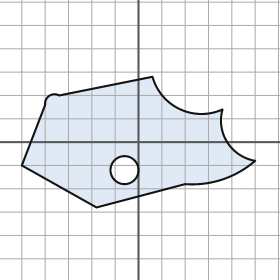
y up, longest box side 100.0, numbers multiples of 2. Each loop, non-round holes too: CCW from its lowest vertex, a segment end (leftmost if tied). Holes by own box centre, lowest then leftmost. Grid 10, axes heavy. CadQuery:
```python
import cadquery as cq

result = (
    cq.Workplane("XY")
    .moveTo(-18.0, -28.0)
    .lineTo(20.0, -18.0)
    .threePointArc((36.0, -16.0), (50.0, -8.0))
    .threePointArc((38.0, 0.0), (36.0, 14.0))
    .threePointArc((18.0, 14.0), (6.0, 28.0))
    .lineTo(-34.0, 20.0)
    .threePointArc((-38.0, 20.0), (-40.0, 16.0))
    .lineTo(-50.0, -10.0)
    .close()
    .moveTo(-6.0, -12.0)
    .circle(6.0)
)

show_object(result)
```